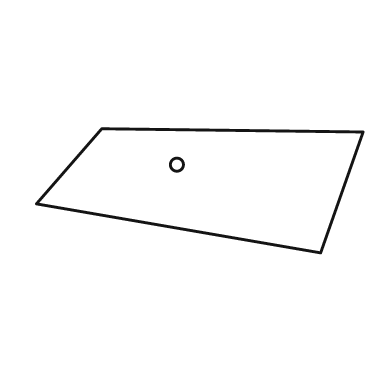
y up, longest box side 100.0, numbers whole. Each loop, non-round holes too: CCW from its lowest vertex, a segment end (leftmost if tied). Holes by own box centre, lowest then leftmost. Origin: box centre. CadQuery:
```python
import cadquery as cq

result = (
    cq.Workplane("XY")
    .moveTo(37.0, -19.0)
    .lineTo(50.0, 18.0)
    .lineTo(-30.0, 19.0)
    .lineTo(-50.0, -4.0)
    .close()
    .moveTo(-7.0, 8.0)
    .circle(2.0)
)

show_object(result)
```